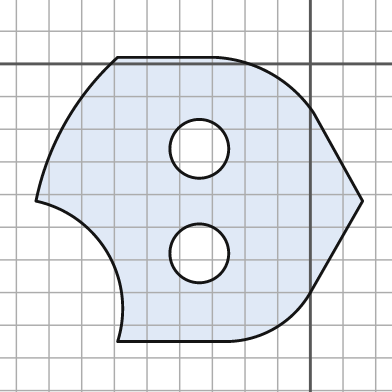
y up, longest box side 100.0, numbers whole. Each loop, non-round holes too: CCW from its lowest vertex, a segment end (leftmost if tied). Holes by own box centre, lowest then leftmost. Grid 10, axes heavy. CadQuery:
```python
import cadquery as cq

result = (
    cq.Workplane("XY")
    .moveTo(-59.0, -85.0)
    .lineTo(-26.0, -85.0)
    .threePointArc((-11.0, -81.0), (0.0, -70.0))
    .lineTo(16.0, -42.0)
    .lineTo(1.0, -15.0)
    .threePointArc((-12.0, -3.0), (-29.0, 2.0))
    .lineTo(-59.0, 2.0)
    .threePointArc((-75.0, -18.0), (-84.0, -42.0))
    .threePointArc((-62.0, -58.0), (-59.0, -85.0))
    .close()
    .moveTo(-34.0, -58.0)
    .circle(9.0)
    .moveTo(-34.0, -26.0)
    .circle(9.0)
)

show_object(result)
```